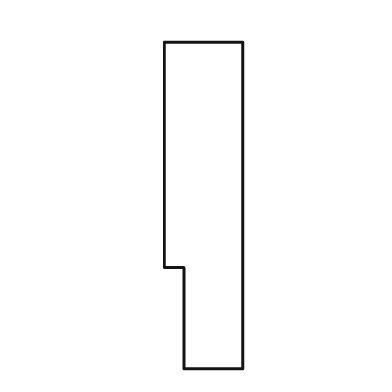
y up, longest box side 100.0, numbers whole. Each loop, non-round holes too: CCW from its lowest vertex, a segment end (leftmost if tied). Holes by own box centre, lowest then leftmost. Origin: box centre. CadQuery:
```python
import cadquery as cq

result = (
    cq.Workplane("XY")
    .moveTo(-6.0, -50.0)
    .lineTo(12.0, -50.0)
    .lineTo(12.0, 50.0)
    .lineTo(-12.0, 50.0)
    .lineTo(-12.0, -19.0)
    .lineTo(-6.0, -19.0)
    .close()
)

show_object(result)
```